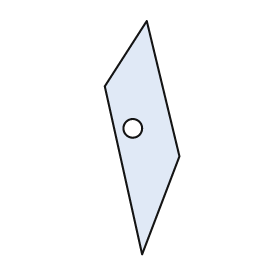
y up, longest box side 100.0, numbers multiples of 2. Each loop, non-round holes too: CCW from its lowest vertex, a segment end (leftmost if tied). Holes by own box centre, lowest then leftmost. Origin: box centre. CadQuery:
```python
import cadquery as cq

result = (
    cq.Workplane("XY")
    .moveTo(0.0, -50.0)
    .lineTo(16.0, -8.0)
    .lineTo(2.0, 50.0)
    .lineTo(-16.0, 22.0)
    .close()
    .moveTo(-4.0, 4.0)
    .circle(4.0)
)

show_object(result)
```